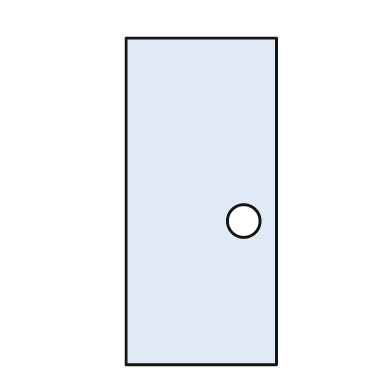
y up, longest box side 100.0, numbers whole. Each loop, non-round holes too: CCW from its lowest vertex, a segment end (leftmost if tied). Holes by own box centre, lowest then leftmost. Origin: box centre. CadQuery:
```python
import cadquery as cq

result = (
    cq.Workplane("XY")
    .moveTo(-23.0, -50.0)
    .lineTo(23.0, -50.0)
    .lineTo(23.0, 50.0)
    .lineTo(-23.0, 50.0)
    .close()
    .moveTo(13.0, -6.0)
    .circle(5.0)
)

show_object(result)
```